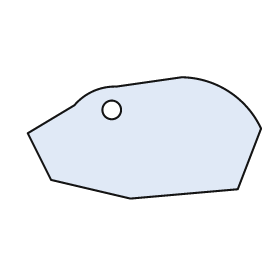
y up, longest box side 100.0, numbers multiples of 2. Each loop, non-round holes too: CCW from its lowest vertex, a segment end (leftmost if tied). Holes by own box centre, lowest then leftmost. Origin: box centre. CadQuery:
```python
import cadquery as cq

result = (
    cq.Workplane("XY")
    .moveTo(-6.0, -26.0)
    .lineTo(40.0, -22.0)
    .lineTo(50.0, 4.0)
    .threePointArc((36.0, 20.0), (16.0, 26.0))
    .lineTo(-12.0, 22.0)
    .threePointArc((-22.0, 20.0), (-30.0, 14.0))
    .lineTo(-50.0, 2.0)
    .lineTo(-40.0, -18.0)
    .close()
    .moveTo(-14.0, 12.0)
    .circle(4.0)
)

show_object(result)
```